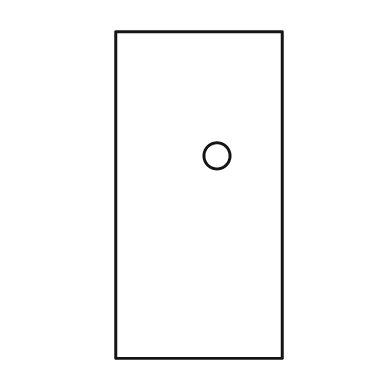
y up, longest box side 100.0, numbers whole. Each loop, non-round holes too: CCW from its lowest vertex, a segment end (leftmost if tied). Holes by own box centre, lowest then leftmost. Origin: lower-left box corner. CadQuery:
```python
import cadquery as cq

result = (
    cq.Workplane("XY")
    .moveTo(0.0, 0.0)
    .lineTo(51.0, 0.0)
    .lineTo(51.0, 100.0)
    .lineTo(0.0, 100.0)
    .close()
    .moveTo(31.0, 62.0)
    .circle(4.0)
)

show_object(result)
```